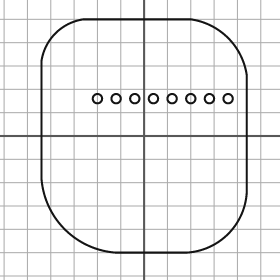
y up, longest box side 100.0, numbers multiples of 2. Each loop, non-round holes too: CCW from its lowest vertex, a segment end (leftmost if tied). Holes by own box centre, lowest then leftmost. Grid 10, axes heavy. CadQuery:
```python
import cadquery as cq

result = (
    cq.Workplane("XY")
    .moveTo(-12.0, -50.0)
    .lineTo(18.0, -50.0)
    .threePointArc((36.0, -42.0), (44.0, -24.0))
    .lineTo(44.0, 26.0)
    .threePointArc((36.0, 42.0), (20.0, 50.0))
    .lineTo(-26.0, 50.0)
    .threePointArc((-38.0, 44.0), (-44.0, 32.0))
    .lineTo(-44.0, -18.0)
    .threePointArc((-34.0, -40.0), (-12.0, -50.0))
    .close()
    .moveTo(-20.0, 16.0)
    .circle(2.0)
    .moveTo(-12.0, 16.0)
    .circle(2.0)
    .moveTo(-4.0, 16.0)
    .circle(2.0)
    .moveTo(4.0, 16.0)
    .circle(2.0)
    .moveTo(12.0, 16.0)
    .circle(2.0)
    .moveTo(20.0, 16.0)
    .circle(2.0)
    .moveTo(28.0, 16.0)
    .circle(2.0)
    .moveTo(36.0, 16.0)
    .circle(2.0)
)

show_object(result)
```